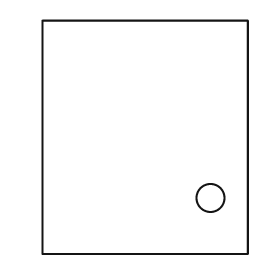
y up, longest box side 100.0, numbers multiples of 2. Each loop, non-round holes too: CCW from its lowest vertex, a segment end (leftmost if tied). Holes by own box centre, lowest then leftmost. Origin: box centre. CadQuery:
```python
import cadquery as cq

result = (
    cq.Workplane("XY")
    .moveTo(-44.0, -50.0)
    .lineTo(44.0, -50.0)
    .lineTo(44.0, 50.0)
    .lineTo(-44.0, 50.0)
    .close()
    .moveTo(28.0, -26.0)
    .circle(6.0)
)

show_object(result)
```